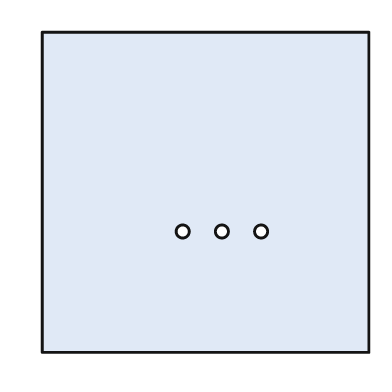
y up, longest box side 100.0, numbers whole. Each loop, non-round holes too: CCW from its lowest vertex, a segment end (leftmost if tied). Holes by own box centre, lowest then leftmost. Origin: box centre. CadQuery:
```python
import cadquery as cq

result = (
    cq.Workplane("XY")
    .moveTo(-50.0, -49.0)
    .lineTo(50.0, -49.0)
    .lineTo(50.0, 49.0)
    .lineTo(-50.0, 49.0)
    .close()
    .moveTo(-7.0, -12.0)
    .circle(2.0)
    .moveTo(5.0, -12.0)
    .circle(2.0)
    .moveTo(17.0, -12.0)
    .circle(2.0)
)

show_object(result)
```